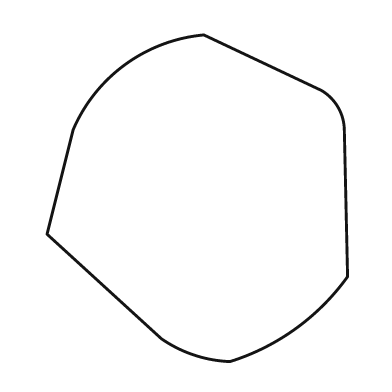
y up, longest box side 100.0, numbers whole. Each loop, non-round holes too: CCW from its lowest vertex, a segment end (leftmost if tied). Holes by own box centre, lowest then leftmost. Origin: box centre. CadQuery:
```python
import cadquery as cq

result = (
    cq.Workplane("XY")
    .moveTo(10.0, -50.0)
    .threePointArc((30.0, -40.0), (46.0, -24.0))
    .lineTo(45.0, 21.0)
    .threePointArc((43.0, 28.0), (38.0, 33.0))
    .lineTo(2.0, 50.0)
    .threePointArc((-22.0, 41.0), (-38.0, 21.0))
    .lineTo(-46.0, -11.0)
    .lineTo(-11.0, -43.0)
    .threePointArc((-1.0, -48.0), (10.0, -50.0))
    .close()
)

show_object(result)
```